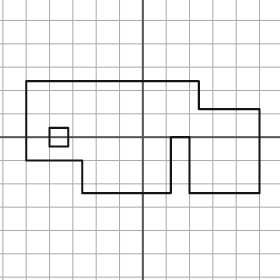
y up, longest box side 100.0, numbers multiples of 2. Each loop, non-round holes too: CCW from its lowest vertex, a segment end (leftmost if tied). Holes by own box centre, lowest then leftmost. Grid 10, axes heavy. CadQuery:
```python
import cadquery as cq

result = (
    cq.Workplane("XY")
    .moveTo(-26.0, -24.0)
    .lineTo(12.0, -24.0)
    .lineTo(12.0, 0.0)
    .lineTo(20.0, 0.0)
    .lineTo(20.0, -24.0)
    .lineTo(50.0, -24.0)
    .lineTo(50.0, 12.0)
    .lineTo(24.0, 12.0)
    .lineTo(24.0, 24.0)
    .lineTo(-50.0, 24.0)
    .lineTo(-50.0, -10.0)
    .lineTo(-26.0, -10.0)
    .close()
    .moveTo(-40.0, -4.0)
    .lineTo(-32.0, -4.0)
    .lineTo(-32.0, 4.0)
    .lineTo(-40.0, 4.0)
    .close()
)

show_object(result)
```